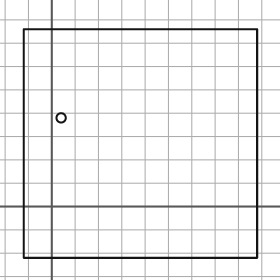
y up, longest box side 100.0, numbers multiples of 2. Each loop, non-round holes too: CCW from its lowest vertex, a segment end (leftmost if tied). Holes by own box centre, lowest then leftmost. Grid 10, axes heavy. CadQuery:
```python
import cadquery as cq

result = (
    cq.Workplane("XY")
    .moveTo(-12.0, -22.0)
    .lineTo(88.0, -22.0)
    .lineTo(88.0, 76.0)
    .lineTo(-12.0, 76.0)
    .close()
    .moveTo(4.0, 38.0)
    .circle(2.0)
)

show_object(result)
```